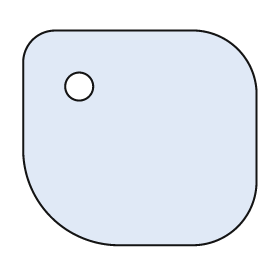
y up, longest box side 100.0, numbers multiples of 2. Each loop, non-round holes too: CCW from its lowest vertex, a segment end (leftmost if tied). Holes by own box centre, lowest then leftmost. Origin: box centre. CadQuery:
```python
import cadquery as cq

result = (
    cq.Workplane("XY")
    .moveTo(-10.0, -46.0)
    .lineTo(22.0, -46.0)
    .threePointArc((42.0, -38.0), (50.0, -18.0))
    .lineTo(50.0, 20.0)
    .threePointArc((42.0, 38.0), (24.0, 46.0))
    .lineTo(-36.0, 46.0)
    .threePointArc((-46.0, 42.0), (-50.0, 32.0))
    .lineTo(-50.0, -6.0)
    .threePointArc((-38.0, -34.0), (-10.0, -46.0))
    .close()
    .moveTo(-26.0, 22.0)
    .circle(6.0)
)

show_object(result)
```